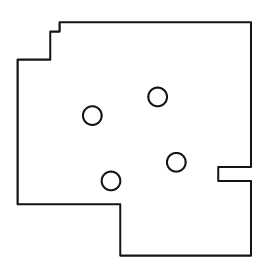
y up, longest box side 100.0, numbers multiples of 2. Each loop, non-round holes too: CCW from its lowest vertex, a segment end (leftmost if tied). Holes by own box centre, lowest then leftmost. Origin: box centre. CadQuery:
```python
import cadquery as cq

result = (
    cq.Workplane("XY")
    .moveTo(-6.0, -50.0)
    .lineTo(50.0, -50.0)
    .lineTo(50.0, -18.0)
    .lineTo(36.0, -18.0)
    .lineTo(36.0, -12.0)
    .lineTo(50.0, -12.0)
    .lineTo(50.0, 50.0)
    .lineTo(-32.0, 50.0)
    .lineTo(-32.0, 46.0)
    .lineTo(-36.0, 46.0)
    .lineTo(-36.0, 34.0)
    .lineTo(-50.0, 34.0)
    .lineTo(-50.0, -28.0)
    .lineTo(-6.0, -28.0)
    .close()
    .moveTo(-10.0, -18.0)
    .circle(4.0)
    .moveTo(18.0, -10.0)
    .circle(4.0)
    .moveTo(-18.0, 10.0)
    .circle(4.0)
    .moveTo(10.0, 18.0)
    .circle(4.0)
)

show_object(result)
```